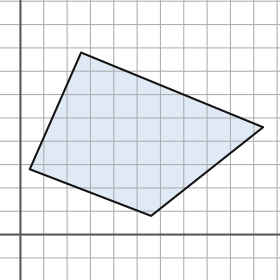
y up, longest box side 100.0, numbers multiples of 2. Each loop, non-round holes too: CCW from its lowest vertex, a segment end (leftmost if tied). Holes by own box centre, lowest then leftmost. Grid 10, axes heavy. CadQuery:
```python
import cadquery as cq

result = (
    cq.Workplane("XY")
    .moveTo(56.0, 8.0)
    .lineTo(104.0, 46.0)
    .lineTo(26.0, 78.0)
    .lineTo(4.0, 28.0)
    .close()
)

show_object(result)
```